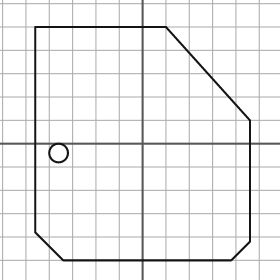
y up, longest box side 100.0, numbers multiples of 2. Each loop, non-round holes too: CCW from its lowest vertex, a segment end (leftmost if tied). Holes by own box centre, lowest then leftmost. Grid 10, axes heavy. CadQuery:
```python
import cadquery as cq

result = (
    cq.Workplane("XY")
    .moveTo(-34.0, -50.0)
    .lineTo(38.0, -50.0)
    .lineTo(46.0, -42.0)
    .lineTo(46.0, 10.0)
    .lineTo(10.0, 50.0)
    .lineTo(-46.0, 50.0)
    .lineTo(-46.0, -38.0)
    .close()
    .moveTo(-36.0, -4.0)
    .circle(4.0)
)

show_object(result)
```